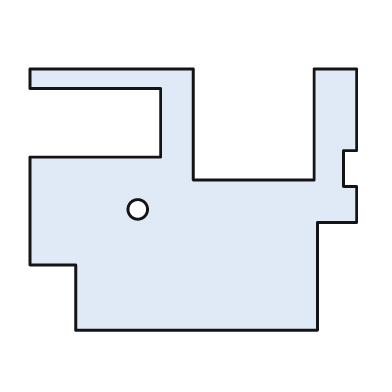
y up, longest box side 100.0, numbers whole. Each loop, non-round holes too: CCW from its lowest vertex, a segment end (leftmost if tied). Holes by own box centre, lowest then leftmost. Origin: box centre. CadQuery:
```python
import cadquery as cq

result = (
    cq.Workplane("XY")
    .moveTo(-36.0, -40.0)
    .lineTo(38.0, -40.0)
    .lineTo(38.0, -7.0)
    .lineTo(50.0, -7.0)
    .lineTo(50.0, 4.0)
    .lineTo(46.0, 4.0)
    .lineTo(46.0, 15.0)
    .lineTo(50.0, 15.0)
    .lineTo(50.0, 40.0)
    .lineTo(37.0, 40.0)
    .lineTo(37.0, 6.0)
    .lineTo(0.0, 6.0)
    .lineTo(0.0, 40.0)
    .lineTo(-50.0, 40.0)
    .lineTo(-50.0, 34.0)
    .lineTo(-10.0, 34.0)
    .lineTo(-10.0, 13.0)
    .lineTo(-50.0, 13.0)
    .lineTo(-50.0, -20.0)
    .lineTo(-36.0, -20.0)
    .close()
    .moveTo(-17.0, -3.0)
    .circle(3.0)
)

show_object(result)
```